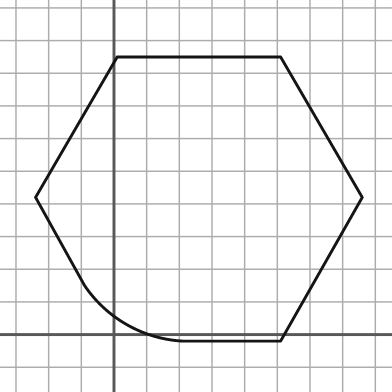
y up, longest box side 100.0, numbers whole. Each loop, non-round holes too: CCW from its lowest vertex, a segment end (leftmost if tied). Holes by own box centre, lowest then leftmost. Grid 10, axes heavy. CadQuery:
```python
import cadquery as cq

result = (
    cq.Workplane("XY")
    .moveTo(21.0, -2.0)
    .lineTo(51.0, -2.0)
    .lineTo(76.0, 42.0)
    .lineTo(51.0, 85.0)
    .lineTo(1.0, 85.0)
    .lineTo(-24.0, 42.0)
    .lineTo(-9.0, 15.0)
    .threePointArc((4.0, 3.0), (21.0, -2.0))
    .close()
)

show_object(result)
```